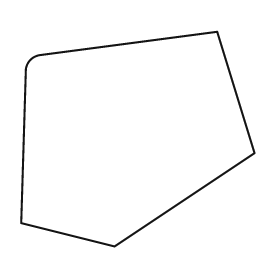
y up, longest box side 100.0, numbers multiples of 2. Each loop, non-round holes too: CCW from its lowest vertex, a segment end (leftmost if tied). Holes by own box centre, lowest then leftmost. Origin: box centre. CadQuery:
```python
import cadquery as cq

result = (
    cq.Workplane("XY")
    .moveTo(-10.0, -46.0)
    .lineTo(50.0, -6.0)
    .lineTo(34.0, 46.0)
    .lineTo(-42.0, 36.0)
    .threePointArc((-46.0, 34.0), (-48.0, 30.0))
    .lineTo(-50.0, -36.0)
    .close()
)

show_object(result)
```